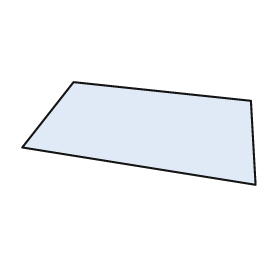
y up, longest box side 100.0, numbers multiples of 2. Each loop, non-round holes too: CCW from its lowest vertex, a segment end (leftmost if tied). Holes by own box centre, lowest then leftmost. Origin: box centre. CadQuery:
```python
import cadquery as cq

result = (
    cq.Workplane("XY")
    .moveTo(50.0, -22.0)
    .lineTo(48.0, 14.0)
    .lineTo(-28.0, 22.0)
    .lineTo(-50.0, -6.0)
    .close()
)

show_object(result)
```